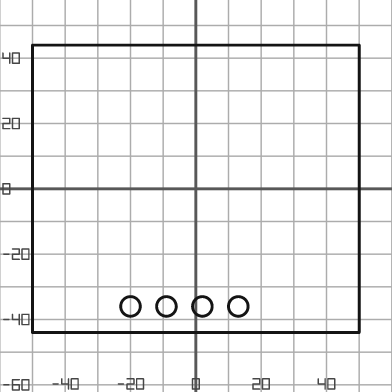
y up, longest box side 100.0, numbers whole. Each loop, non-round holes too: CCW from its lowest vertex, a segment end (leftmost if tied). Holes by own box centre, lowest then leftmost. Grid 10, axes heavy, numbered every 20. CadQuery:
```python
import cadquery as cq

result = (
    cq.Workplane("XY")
    .moveTo(-50.0, -44.0)
    .lineTo(50.0, -44.0)
    .lineTo(50.0, 44.0)
    .lineTo(-50.0, 44.0)
    .close()
    .moveTo(-20.0, -36.0)
    .circle(3.0)
    .moveTo(-9.0, -36.0)
    .circle(3.0)
    .moveTo(2.0, -36.0)
    .circle(3.0)
    .moveTo(13.0, -36.0)
    .circle(3.0)
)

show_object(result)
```